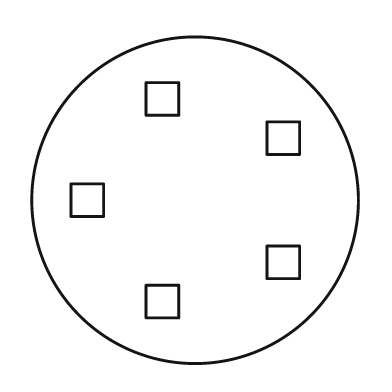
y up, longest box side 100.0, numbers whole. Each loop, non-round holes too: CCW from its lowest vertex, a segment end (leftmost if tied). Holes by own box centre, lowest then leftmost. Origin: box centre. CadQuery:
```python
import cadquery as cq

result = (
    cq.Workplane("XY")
    .moveTo(0.0, 0.0)
    .circle(50.0)
    .moveTo(-15.0, -36.0)
    .lineTo(-5.0, -36.0)
    .lineTo(-5.0, -26.0)
    .lineTo(-15.0, -26.0)
    .close()
    .moveTo(22.0, -24.0)
    .lineTo(32.0, -24.0)
    .lineTo(32.0, -14.0)
    .lineTo(22.0, -14.0)
    .close()
    .moveTo(-38.0, -5.0)
    .lineTo(-28.0, -5.0)
    .lineTo(-28.0, 5.0)
    .lineTo(-38.0, 5.0)
    .close()
    .moveTo(22.0, 14.0)
    .lineTo(32.0, 14.0)
    .lineTo(32.0, 24.0)
    .lineTo(22.0, 24.0)
    .close()
    .moveTo(-15.0, 26.0)
    .lineTo(-5.0, 26.0)
    .lineTo(-5.0, 36.0)
    .lineTo(-15.0, 36.0)
    .close()
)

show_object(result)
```